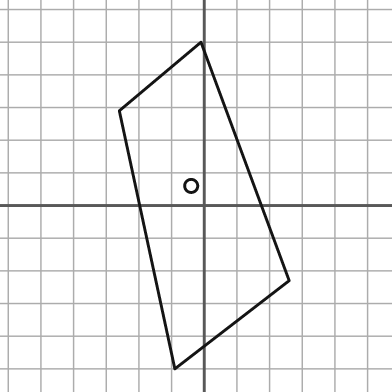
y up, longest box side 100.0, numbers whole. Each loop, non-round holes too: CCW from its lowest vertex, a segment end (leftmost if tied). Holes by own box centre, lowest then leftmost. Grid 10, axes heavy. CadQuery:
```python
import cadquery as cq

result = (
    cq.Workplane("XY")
    .moveTo(-9.0, -50.0)
    .lineTo(26.0, -23.0)
    .lineTo(-1.0, 50.0)
    .lineTo(-26.0, 29.0)
    .close()
    .moveTo(-4.0, 6.0)
    .circle(2.0)
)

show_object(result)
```